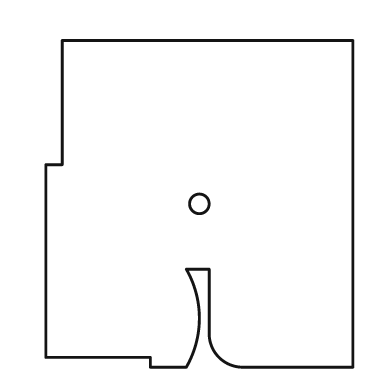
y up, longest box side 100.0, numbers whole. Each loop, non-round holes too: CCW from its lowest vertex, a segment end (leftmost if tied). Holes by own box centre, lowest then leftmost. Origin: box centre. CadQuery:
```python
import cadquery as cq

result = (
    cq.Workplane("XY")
    .moveTo(-15.0, -50.0)
    .lineTo(-4.0, -50.0)
    .threePointArc((0.0, -35.0), (-4.0, -20.0))
    .lineTo(3.0, -20.0)
    .lineTo(3.0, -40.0)
    .threePointArc((6.0, -47.0), (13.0, -50.0))
    .lineTo(47.0, -50.0)
    .lineTo(47.0, 50.0)
    .lineTo(-42.0, 50.0)
    .lineTo(-42.0, 12.0)
    .lineTo(-47.0, 12.0)
    .lineTo(-47.0, -47.0)
    .lineTo(-15.0, -47.0)
    .close()
    .moveTo(0.0, 0.0)
    .circle(3.0)
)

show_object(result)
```